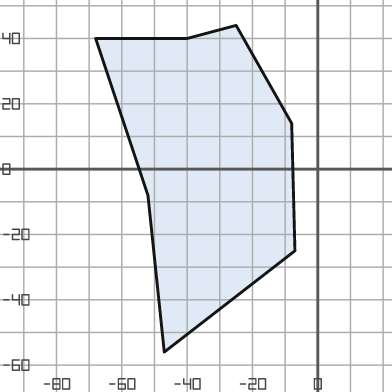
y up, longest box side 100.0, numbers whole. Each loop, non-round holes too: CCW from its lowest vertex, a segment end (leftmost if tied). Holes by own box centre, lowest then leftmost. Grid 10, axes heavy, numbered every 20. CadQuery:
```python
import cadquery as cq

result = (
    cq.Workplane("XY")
    .moveTo(-47.0, -56.0)
    .lineTo(-7.0, -25.0)
    .lineTo(-8.0, 14.0)
    .lineTo(-25.0, 44.0)
    .lineTo(-40.0, 40.0)
    .lineTo(-68.0, 40.0)
    .lineTo(-52.0, -8.0)
    .close()
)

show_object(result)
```